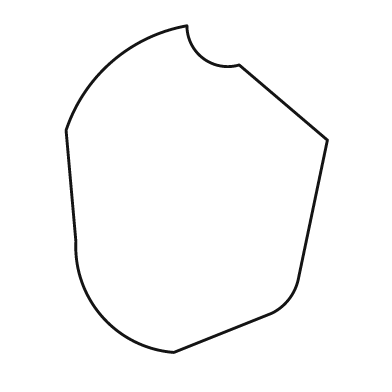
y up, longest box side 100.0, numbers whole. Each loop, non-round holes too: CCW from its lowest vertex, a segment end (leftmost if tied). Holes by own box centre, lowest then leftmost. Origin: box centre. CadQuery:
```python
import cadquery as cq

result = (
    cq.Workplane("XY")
    .moveTo(-7.0, -50.0)
    .lineTo(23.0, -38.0)
    .threePointArc((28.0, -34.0), (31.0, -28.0))
    .lineTo(40.0, 15.0)
    .lineTo(13.0, 38.0)
    .threePointArc((2.0, 40.0), (-3.0, 50.0))
    .threePointArc((-26.0, 39.0), (-40.0, 18.0))
    .lineTo(-37.0, -16.0)
    .threePointArc((-29.0, -39.0), (-7.0, -50.0))
    .close()
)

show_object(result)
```